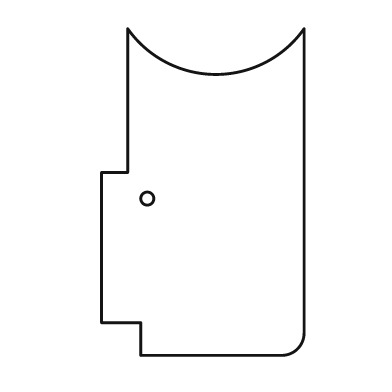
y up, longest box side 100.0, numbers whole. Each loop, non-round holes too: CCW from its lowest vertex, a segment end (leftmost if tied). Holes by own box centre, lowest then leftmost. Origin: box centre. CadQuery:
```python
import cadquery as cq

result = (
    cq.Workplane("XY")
    .moveTo(-19.0, -50.0)
    .lineTo(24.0, -50.0)
    .threePointArc((29.0, -48.0), (31.0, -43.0))
    .lineTo(31.0, 50.0)
    .threePointArc((4.0, 36.0), (-23.0, 50.0))
    .lineTo(-23.0, 6.0)
    .lineTo(-31.0, 6.0)
    .lineTo(-31.0, -40.0)
    .lineTo(-19.0, -40.0)
    .close()
    .moveTo(-17.0, -2.0)
    .circle(2.0)
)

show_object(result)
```